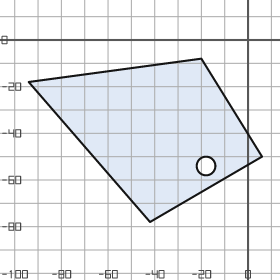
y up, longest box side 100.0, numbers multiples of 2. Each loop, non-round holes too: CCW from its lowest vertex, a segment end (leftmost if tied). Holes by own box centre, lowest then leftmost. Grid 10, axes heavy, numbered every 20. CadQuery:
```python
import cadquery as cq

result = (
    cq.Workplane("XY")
    .moveTo(-42.0, -78.0)
    .lineTo(6.0, -50.0)
    .lineTo(-20.0, -8.0)
    .lineTo(-94.0, -18.0)
    .close()
    .moveTo(-18.0, -54.0)
    .circle(4.0)
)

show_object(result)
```